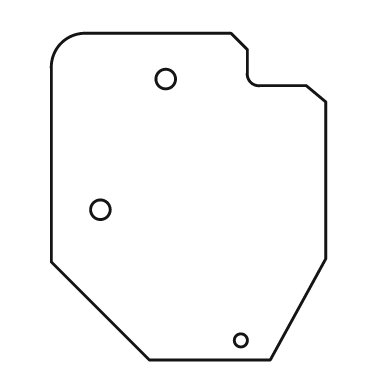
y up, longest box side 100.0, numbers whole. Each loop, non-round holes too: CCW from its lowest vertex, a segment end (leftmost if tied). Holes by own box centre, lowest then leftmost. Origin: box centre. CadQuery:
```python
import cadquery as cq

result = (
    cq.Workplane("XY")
    .moveTo(-12.0, -50.0)
    .lineTo(25.0, -50.0)
    .lineTo(42.0, -19.0)
    .lineTo(42.0, 29.0)
    .lineTo(36.0, 34.0)
    .lineTo(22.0, 34.0)
    .threePointArc((19.0, 35.0), (18.0, 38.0))
    .lineTo(18.0, 45.0)
    .lineTo(13.0, 50.0)
    .lineTo(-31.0, 50.0)
    .threePointArc((-39.0, 47.0), (-42.0, 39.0))
    .lineTo(-42.0, -20.0)
    .close()
    .moveTo(16.0, -44.0)
    .circle(2.0)
    .moveTo(-27.0, -4.0)
    .circle(3.0)
    .moveTo(-7.0, 36.0)
    .circle(3.0)
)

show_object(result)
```